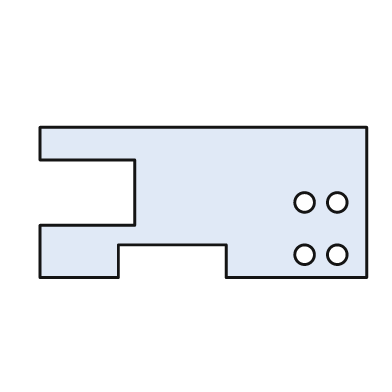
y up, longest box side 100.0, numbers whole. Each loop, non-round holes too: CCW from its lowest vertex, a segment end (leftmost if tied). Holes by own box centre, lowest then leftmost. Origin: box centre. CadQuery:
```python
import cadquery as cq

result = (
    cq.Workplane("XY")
    .moveTo(-50.0, -23.0)
    .lineTo(-26.0, -23.0)
    .lineTo(-26.0, -13.0)
    .lineTo(7.0, -13.0)
    .lineTo(7.0, -23.0)
    .lineTo(50.0, -23.0)
    .lineTo(50.0, 23.0)
    .lineTo(-50.0, 23.0)
    .lineTo(-50.0, 13.0)
    .lineTo(-21.0, 13.0)
    .lineTo(-21.0, -7.0)
    .lineTo(-50.0, -7.0)
    .close()
    .moveTo(31.0, -16.0)
    .circle(3.0)
    .moveTo(41.0, -16.0)
    .circle(3.0)
    .moveTo(31.0, 0.0)
    .circle(3.0)
    .moveTo(41.0, 0.0)
    .circle(3.0)
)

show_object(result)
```